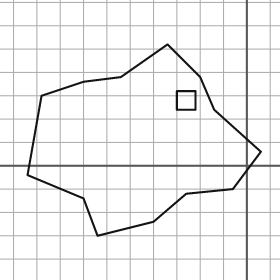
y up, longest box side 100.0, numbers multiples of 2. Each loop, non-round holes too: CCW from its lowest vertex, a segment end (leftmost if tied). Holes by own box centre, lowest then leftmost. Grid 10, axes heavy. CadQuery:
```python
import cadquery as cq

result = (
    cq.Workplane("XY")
    .moveTo(-64.0, -30.0)
    .lineTo(-40.0, -24.0)
    .lineTo(-26.0, -12.0)
    .lineTo(-6.0, -10.0)
    .lineTo(6.0, 6.0)
    .lineTo(-14.0, 24.0)
    .lineTo(-20.0, 38.0)
    .lineTo(-34.0, 52.0)
    .lineTo(-54.0, 38.0)
    .lineTo(-70.0, 36.0)
    .lineTo(-88.0, 30.0)
    .lineTo(-94.0, -4.0)
    .lineTo(-70.0, -14.0)
    .close()
    .moveTo(-30.0, 24.0)
    .lineTo(-22.0, 24.0)
    .lineTo(-22.0, 32.0)
    .lineTo(-30.0, 32.0)
    .close()
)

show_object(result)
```